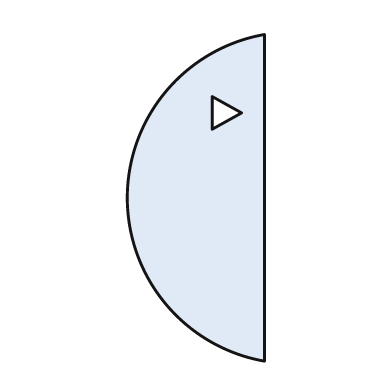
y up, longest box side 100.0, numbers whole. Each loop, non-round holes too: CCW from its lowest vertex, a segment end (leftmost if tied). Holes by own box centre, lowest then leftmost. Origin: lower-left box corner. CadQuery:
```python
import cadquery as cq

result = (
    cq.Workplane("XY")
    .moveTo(42.0, 0.0)
    .lineTo(42.0, 100.0)
    .threePointArc((0.0, 50.0), (42.0, 0.0))
    .close()
    .moveTo(26.0, 71.0)
    .lineTo(35.0, 76.0)
    .lineTo(26.0, 81.0)
    .close()
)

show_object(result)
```